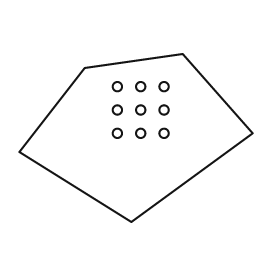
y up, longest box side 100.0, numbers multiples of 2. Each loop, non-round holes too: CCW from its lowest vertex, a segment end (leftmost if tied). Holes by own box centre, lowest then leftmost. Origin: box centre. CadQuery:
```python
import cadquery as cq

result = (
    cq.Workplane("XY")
    .moveTo(-2.0, -36.0)
    .lineTo(50.0, 2.0)
    .lineTo(20.0, 36.0)
    .lineTo(-22.0, 30.0)
    .lineTo(-50.0, -6.0)
    .close()
    .moveTo(-8.0, 2.0)
    .circle(2.0)
    .moveTo(2.0, 2.0)
    .circle(2.0)
    .moveTo(12.0, 2.0)
    .circle(2.0)
    .moveTo(-8.0, 12.0)
    .circle(2.0)
    .moveTo(2.0, 12.0)
    .circle(2.0)
    .moveTo(12.0, 12.0)
    .circle(2.0)
    .moveTo(-8.0, 22.0)
    .circle(2.0)
    .moveTo(2.0, 22.0)
    .circle(2.0)
    .moveTo(12.0, 22.0)
    .circle(2.0)
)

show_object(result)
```